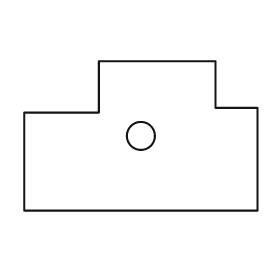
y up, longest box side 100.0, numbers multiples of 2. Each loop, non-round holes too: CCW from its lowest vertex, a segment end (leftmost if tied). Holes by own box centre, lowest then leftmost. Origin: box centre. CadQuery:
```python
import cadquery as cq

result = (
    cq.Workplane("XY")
    .moveTo(-50.0, -32.0)
    .lineTo(50.0, -32.0)
    .lineTo(50.0, 12.0)
    .lineTo(32.0, 12.0)
    .lineTo(32.0, 32.0)
    .lineTo(-18.0, 32.0)
    .lineTo(-18.0, 10.0)
    .lineTo(-50.0, 10.0)
    .close()
    .moveTo(0.0, 0.0)
    .circle(6.0)
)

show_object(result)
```